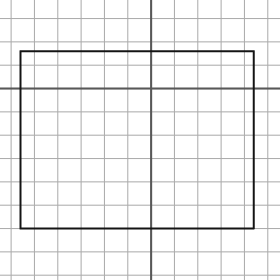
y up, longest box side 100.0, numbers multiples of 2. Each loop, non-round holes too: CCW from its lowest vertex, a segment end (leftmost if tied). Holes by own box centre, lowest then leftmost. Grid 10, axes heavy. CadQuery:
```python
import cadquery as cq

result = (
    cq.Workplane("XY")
    .moveTo(-56.0, -60.0)
    .lineTo(44.0, -60.0)
    .lineTo(44.0, 16.0)
    .lineTo(-56.0, 16.0)
    .close()
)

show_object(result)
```